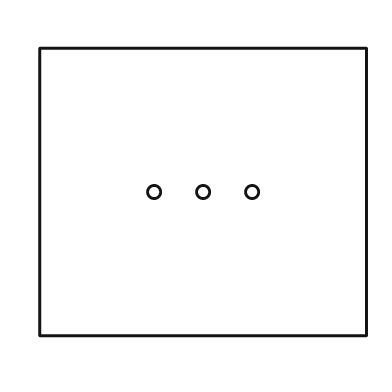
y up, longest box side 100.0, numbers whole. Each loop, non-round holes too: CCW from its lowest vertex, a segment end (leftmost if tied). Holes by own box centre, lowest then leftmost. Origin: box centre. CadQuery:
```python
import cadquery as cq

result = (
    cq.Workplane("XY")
    .moveTo(-50.0, -44.0)
    .lineTo(50.0, -44.0)
    .lineTo(50.0, 44.0)
    .lineTo(-50.0, 44.0)
    .close()
    .moveTo(-15.0, 0.0)
    .circle(2.0)
    .moveTo(0.0, 0.0)
    .circle(2.0)
    .moveTo(15.0, 0.0)
    .circle(2.0)
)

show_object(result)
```